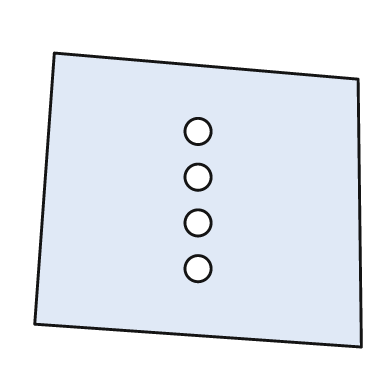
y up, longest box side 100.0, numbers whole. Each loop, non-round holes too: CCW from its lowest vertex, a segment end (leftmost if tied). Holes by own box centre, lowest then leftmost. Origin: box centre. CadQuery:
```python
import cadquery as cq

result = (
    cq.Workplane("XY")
    .moveTo(50.0, -45.0)
    .lineTo(49.0, 37.0)
    .lineTo(-44.0, 45.0)
    .lineTo(-50.0, -38.0)
    .close()
    .moveTo(0.0, -21.0)
    .circle(4.0)
    .moveTo(0.0, -7.0)
    .circle(4.0)
    .moveTo(0.0, 7.0)
    .circle(4.0)
    .moveTo(0.0, 21.0)
    .circle(4.0)
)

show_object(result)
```